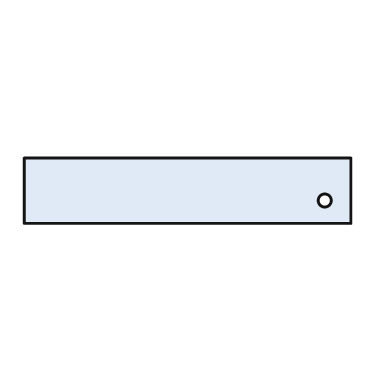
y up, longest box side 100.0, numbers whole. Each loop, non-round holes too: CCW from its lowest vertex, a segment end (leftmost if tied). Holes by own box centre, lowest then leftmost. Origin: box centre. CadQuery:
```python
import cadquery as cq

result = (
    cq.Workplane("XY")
    .moveTo(-50.0, -10.0)
    .lineTo(50.0, -10.0)
    .lineTo(50.0, 10.0)
    .lineTo(-50.0, 10.0)
    .close()
    .moveTo(42.0, -3.0)
    .circle(2.0)
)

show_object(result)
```